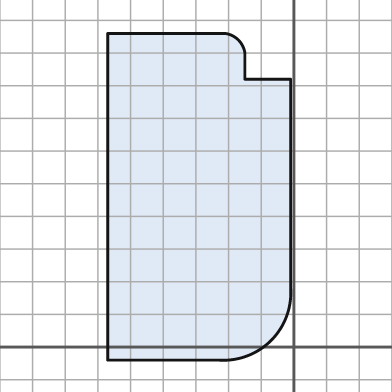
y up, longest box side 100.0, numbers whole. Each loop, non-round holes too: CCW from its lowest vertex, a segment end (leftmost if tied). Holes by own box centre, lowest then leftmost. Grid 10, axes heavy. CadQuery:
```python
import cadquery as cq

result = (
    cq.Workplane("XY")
    .moveTo(-57.0, -4.0)
    .lineTo(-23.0, -4.0)
    .threePointArc((-7.0, 2.0), (-1.0, 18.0))
    .lineTo(-1.0, 82.0)
    .lineTo(-15.0, 82.0)
    .lineTo(-15.0, 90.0)
    .threePointArc((-17.0, 94.0), (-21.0, 96.0))
    .lineTo(-57.0, 96.0)
    .close()
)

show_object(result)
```